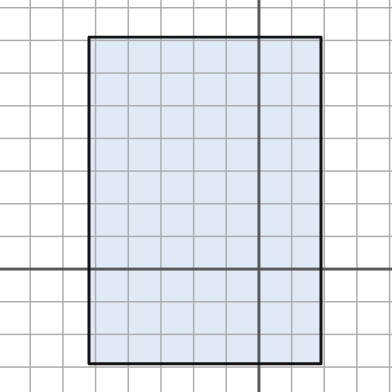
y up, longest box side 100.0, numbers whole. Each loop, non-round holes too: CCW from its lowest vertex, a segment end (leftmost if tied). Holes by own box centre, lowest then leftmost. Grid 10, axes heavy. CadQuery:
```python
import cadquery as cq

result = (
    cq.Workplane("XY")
    .moveTo(-52.0, -29.0)
    .lineTo(19.0, -29.0)
    .lineTo(19.0, 71.0)
    .lineTo(-52.0, 71.0)
    .close()
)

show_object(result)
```